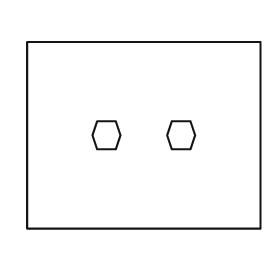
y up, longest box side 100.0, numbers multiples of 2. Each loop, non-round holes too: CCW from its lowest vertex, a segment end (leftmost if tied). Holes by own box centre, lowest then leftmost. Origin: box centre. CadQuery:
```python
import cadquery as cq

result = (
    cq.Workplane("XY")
    .moveTo(-50.0, -40.0)
    .lineTo(50.0, -40.0)
    .lineTo(50.0, 40.0)
    .lineTo(-50.0, 40.0)
    .close()
    .moveTo(-20.0, -6.0)
    .lineTo(-12.0, -6.0)
    .lineTo(-10.0, 0.0)
    .lineTo(-12.0, 6.0)
    .lineTo(-20.0, 6.0)
    .lineTo(-22.0, 0.0)
    .close()
    .moveTo(12.0, -6.0)
    .lineTo(20.0, -6.0)
    .lineTo(22.0, 0.0)
    .lineTo(20.0, 6.0)
    .lineTo(12.0, 6.0)
    .lineTo(10.0, 0.0)
    .close()
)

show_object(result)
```